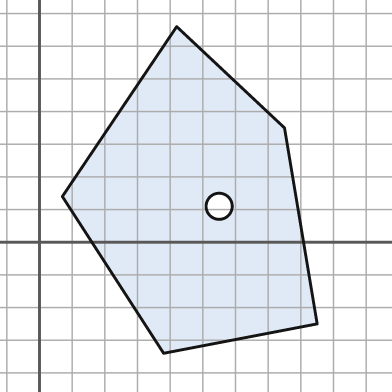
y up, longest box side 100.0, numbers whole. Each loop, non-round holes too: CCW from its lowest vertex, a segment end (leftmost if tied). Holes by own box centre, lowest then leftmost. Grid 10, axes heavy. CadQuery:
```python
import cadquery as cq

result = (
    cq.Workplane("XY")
    .moveTo(38.0, -34.0)
    .lineTo(85.0, -25.0)
    .lineTo(75.0, 35.0)
    .lineTo(42.0, 66.0)
    .lineTo(7.0, 14.0)
    .close()
    .moveTo(55.0, 11.0)
    .circle(4.0)
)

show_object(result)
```